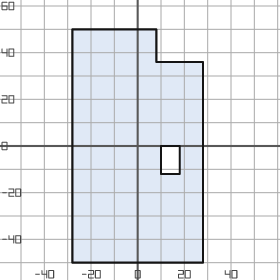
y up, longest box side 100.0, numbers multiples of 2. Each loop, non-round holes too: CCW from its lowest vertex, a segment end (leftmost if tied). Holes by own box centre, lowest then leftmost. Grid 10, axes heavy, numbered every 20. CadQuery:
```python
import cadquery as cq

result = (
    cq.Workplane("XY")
    .moveTo(-28.0, -50.0)
    .lineTo(28.0, -50.0)
    .lineTo(28.0, 36.0)
    .lineTo(8.0, 36.0)
    .lineTo(8.0, 50.0)
    .lineTo(-28.0, 50.0)
    .close()
    .moveTo(10.0, -12.0)
    .lineTo(18.0, -12.0)
    .lineTo(18.0, 0.0)
    .lineTo(10.0, 0.0)
    .close()
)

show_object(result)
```